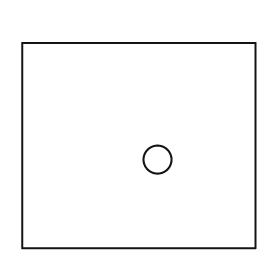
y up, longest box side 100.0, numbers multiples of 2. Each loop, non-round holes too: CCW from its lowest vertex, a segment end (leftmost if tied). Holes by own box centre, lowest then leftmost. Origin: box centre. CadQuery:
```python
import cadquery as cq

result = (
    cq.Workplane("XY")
    .moveTo(-50.0, -44.0)
    .lineTo(50.0, -44.0)
    .lineTo(50.0, 44.0)
    .lineTo(-50.0, 44.0)
    .close()
    .moveTo(8.0, -6.0)
    .circle(6.0)
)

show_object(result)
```